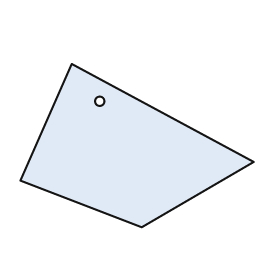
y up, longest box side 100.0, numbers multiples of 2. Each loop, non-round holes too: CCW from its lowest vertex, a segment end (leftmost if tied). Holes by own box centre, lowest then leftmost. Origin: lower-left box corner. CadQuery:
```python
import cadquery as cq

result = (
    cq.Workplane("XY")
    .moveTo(52.0, 0.0)
    .lineTo(100.0, 28.0)
    .lineTo(22.0, 70.0)
    .lineTo(0.0, 20.0)
    .close()
    .moveTo(34.0, 54.0)
    .circle(2.0)
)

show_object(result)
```